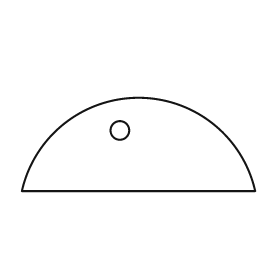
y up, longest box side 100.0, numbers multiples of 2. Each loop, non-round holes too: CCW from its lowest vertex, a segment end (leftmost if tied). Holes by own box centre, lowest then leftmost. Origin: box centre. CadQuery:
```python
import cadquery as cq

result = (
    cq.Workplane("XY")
    .moveTo(-50.0, -20.0)
    .lineTo(50.0, -20.0)
    .threePointArc((0.0, 20.0), (-50.0, -20.0))
    .close()
    .moveTo(-8.0, 6.0)
    .circle(4.0)
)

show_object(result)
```